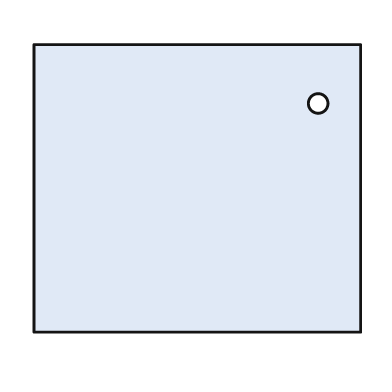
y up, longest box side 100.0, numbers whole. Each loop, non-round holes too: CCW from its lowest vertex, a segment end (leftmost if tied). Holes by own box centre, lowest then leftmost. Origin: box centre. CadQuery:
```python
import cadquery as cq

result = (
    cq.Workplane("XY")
    .moveTo(-50.0, -44.0)
    .lineTo(50.0, -44.0)
    .lineTo(50.0, 44.0)
    .lineTo(-50.0, 44.0)
    .close()
    .moveTo(37.0, 26.0)
    .circle(3.0)
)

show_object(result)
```